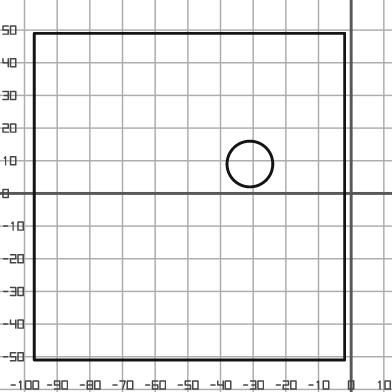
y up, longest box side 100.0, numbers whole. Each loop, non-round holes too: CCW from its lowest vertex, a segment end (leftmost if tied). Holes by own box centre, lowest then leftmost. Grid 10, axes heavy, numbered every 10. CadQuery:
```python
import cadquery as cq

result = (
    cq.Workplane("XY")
    .moveTo(-97.0, -51.0)
    .lineTo(-2.0, -51.0)
    .lineTo(-2.0, 49.0)
    .lineTo(-97.0, 49.0)
    .close()
    .moveTo(-31.0, 9.0)
    .circle(7.0)
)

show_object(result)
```